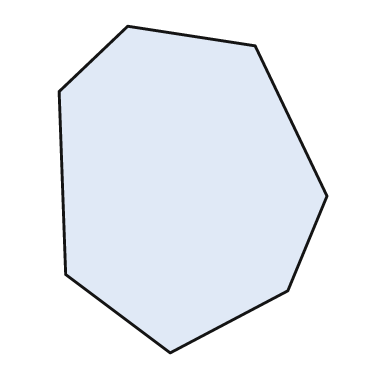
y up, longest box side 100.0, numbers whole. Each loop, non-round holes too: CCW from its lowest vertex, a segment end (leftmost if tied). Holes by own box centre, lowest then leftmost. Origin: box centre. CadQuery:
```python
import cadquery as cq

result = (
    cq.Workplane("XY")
    .moveTo(-7.0, -50.0)
    .lineTo(29.0, -31.0)
    .lineTo(41.0, -2.0)
    .lineTo(19.0, 44.0)
    .lineTo(-20.0, 50.0)
    .lineTo(-41.0, 30.0)
    .lineTo(-39.0, -26.0)
    .close()
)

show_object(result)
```